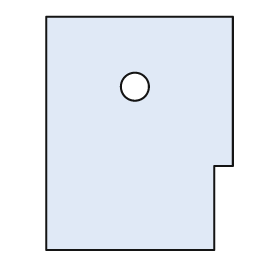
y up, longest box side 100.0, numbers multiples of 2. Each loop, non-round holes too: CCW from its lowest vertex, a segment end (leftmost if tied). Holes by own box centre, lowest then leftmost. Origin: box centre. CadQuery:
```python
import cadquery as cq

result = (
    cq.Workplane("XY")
    .moveTo(-40.0, -50.0)
    .lineTo(32.0, -50.0)
    .lineTo(32.0, -14.0)
    .lineTo(40.0, -14.0)
    .lineTo(40.0, 50.0)
    .lineTo(-40.0, 50.0)
    .close()
    .moveTo(-2.0, 20.0)
    .circle(6.0)
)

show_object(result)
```